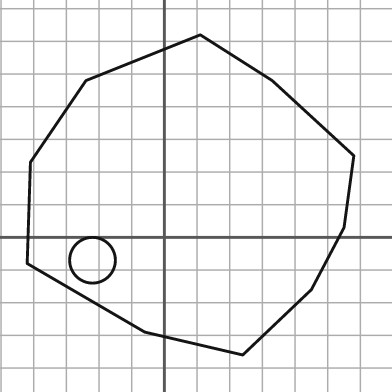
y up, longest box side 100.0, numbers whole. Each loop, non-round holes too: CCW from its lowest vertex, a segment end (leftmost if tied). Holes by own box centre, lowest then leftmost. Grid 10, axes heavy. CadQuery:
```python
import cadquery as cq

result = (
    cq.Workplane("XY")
    .moveTo(24.0, -36.0)
    .lineTo(45.0, -16.0)
    .lineTo(55.0, 3.0)
    .lineTo(58.0, 25.0)
    .lineTo(33.0, 48.0)
    .lineTo(11.0, 62.0)
    .lineTo(-24.0, 48.0)
    .lineTo(-41.0, 23.0)
    .lineTo(-42.0, -8.0)
    .lineTo(-6.0, -29.0)
    .close()
    .moveTo(-22.0, -7.0)
    .circle(7.0)
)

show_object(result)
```